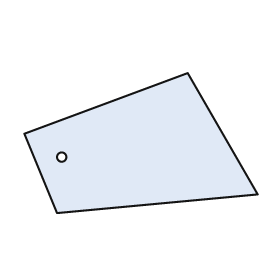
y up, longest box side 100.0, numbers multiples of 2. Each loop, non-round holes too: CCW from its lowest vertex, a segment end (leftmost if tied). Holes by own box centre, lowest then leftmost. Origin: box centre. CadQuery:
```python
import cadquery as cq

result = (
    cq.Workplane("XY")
    .moveTo(-36.0, -30.0)
    .lineTo(50.0, -22.0)
    .lineTo(20.0, 30.0)
    .lineTo(-50.0, 4.0)
    .close()
    .moveTo(-34.0, -6.0)
    .circle(2.0)
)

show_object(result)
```